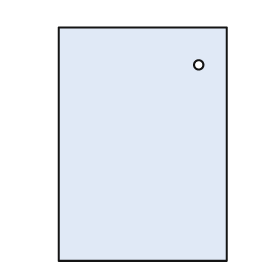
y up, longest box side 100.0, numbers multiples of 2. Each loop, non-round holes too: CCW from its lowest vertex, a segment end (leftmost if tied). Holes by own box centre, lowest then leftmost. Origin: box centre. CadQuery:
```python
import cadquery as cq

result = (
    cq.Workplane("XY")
    .moveTo(-36.0, -50.0)
    .lineTo(36.0, -50.0)
    .lineTo(36.0, 50.0)
    .lineTo(-36.0, 50.0)
    .close()
    .moveTo(24.0, 34.0)
    .circle(2.0)
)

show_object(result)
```